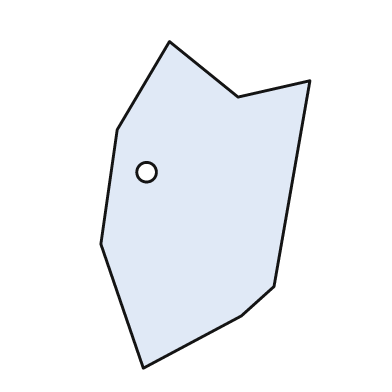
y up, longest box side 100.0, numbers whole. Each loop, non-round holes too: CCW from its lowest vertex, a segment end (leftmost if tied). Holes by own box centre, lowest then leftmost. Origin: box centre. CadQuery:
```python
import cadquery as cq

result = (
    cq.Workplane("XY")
    .moveTo(-19.0, -50.0)
    .lineTo(11.0, -34.0)
    .lineTo(21.0, -25.0)
    .lineTo(32.0, 38.0)
    .lineTo(10.0, 33.0)
    .lineTo(-11.0, 50.0)
    .lineTo(-27.0, 23.0)
    .lineTo(-32.0, -12.0)
    .close()
    .moveTo(-18.0, 10.0)
    .circle(3.0)
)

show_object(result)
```